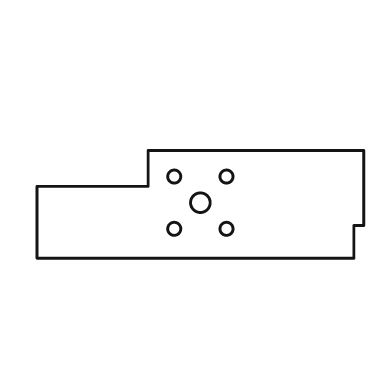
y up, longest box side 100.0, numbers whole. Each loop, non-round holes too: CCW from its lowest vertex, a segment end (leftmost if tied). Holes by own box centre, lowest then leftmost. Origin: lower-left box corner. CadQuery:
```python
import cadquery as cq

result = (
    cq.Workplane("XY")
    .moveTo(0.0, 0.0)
    .lineTo(97.0, 0.0)
    .lineTo(97.0, 10.0)
    .lineTo(100.0, 10.0)
    .lineTo(100.0, 33.0)
    .lineTo(34.0, 33.0)
    .lineTo(34.0, 22.0)
    .lineTo(0.0, 22.0)
    .close()
    .moveTo(42.0, 9.0)
    .circle(2.0)
    .moveTo(58.0, 9.0)
    .circle(2.0)
    .moveTo(50.0, 17.0)
    .circle(3.0)
    .moveTo(42.0, 25.0)
    .circle(2.0)
    .moveTo(58.0, 25.0)
    .circle(2.0)
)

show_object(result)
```